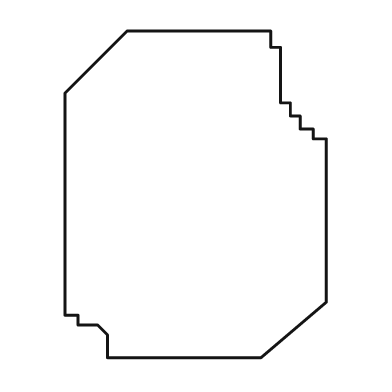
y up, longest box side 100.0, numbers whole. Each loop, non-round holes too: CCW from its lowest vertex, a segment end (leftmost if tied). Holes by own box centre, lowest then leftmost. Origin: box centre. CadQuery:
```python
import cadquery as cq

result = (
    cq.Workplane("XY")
    .moveTo(-27.0, -50.0)
    .lineTo(20.0, -50.0)
    .lineTo(40.0, -33.0)
    .lineTo(40.0, 17.0)
    .lineTo(36.0, 17.0)
    .lineTo(36.0, 20.0)
    .lineTo(32.0, 20.0)
    .lineTo(32.0, 24.0)
    .lineTo(29.0, 24.0)
    .lineTo(29.0, 28.0)
    .lineTo(26.0, 28.0)
    .lineTo(26.0, 45.0)
    .lineTo(23.0, 45.0)
    .lineTo(23.0, 50.0)
    .lineTo(-21.0, 50.0)
    .lineTo(-40.0, 31.0)
    .lineTo(-40.0, -37.0)
    .lineTo(-36.0, -37.0)
    .lineTo(-36.0, -40.0)
    .lineTo(-30.0, -40.0)
    .lineTo(-27.0, -43.0)
    .close()
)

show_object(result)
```